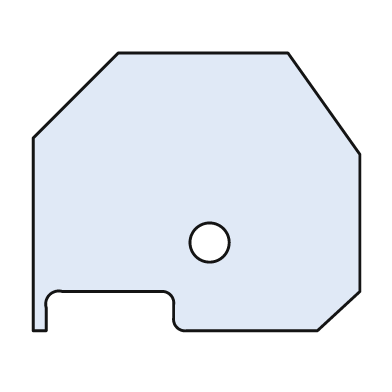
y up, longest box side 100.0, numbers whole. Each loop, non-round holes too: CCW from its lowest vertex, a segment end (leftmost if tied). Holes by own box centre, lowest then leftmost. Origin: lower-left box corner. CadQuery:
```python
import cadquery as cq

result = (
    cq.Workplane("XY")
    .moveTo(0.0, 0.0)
    .lineTo(4.0, 0.0)
    .lineTo(4.0, 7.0)
    .threePointArc((5.0, 11.0), (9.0, 12.0))
    .lineTo(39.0, 12.0)
    .threePointArc((42.0, 11.0), (43.0, 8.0))
    .lineTo(43.0, 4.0)
    .threePointArc((44.0, 1.0), (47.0, 0.0))
    .lineTo(87.0, 0.0)
    .lineTo(100.0, 12.0)
    .lineTo(100.0, 54.0)
    .lineTo(78.0, 85.0)
    .lineTo(26.0, 85.0)
    .lineTo(0.0, 59.0)
    .close()
    .moveTo(54.0, 27.0)
    .circle(6.0)
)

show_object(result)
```